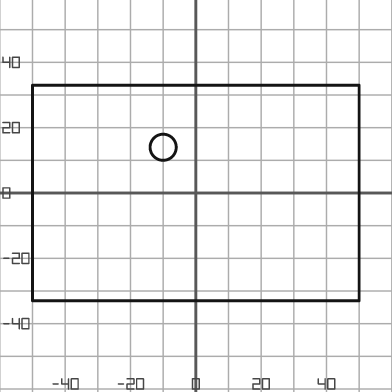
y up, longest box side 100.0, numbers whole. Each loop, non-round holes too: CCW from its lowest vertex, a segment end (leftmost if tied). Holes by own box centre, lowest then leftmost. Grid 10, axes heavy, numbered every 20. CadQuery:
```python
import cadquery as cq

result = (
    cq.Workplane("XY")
    .moveTo(-50.0, -33.0)
    .lineTo(50.0, -33.0)
    .lineTo(50.0, 33.0)
    .lineTo(-50.0, 33.0)
    .close()
    .moveTo(-10.0, 14.0)
    .circle(4.0)
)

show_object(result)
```